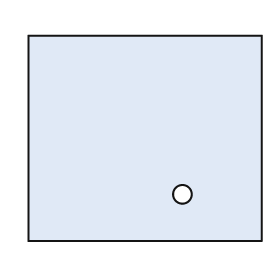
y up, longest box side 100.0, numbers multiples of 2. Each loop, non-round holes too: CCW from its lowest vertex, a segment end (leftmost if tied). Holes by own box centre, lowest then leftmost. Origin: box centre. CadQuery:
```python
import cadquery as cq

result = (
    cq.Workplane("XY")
    .moveTo(-50.0, -44.0)
    .lineTo(50.0, -44.0)
    .lineTo(50.0, 44.0)
    .lineTo(-50.0, 44.0)
    .close()
    .moveTo(16.0, -24.0)
    .circle(4.0)
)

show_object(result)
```